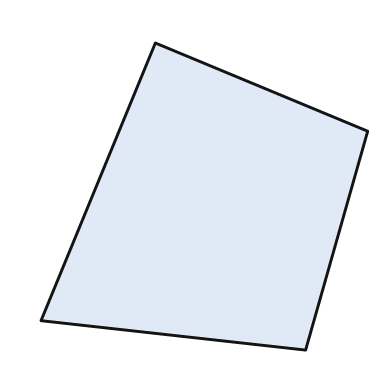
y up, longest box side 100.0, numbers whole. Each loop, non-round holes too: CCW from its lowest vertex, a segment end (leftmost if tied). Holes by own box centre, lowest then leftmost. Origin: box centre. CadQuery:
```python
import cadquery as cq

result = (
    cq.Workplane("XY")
    .moveTo(31.0, -47.0)
    .lineTo(50.0, 20.0)
    .lineTo(-15.0, 47.0)
    .lineTo(-50.0, -38.0)
    .close()
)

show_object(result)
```